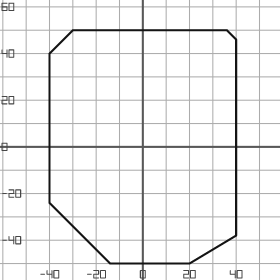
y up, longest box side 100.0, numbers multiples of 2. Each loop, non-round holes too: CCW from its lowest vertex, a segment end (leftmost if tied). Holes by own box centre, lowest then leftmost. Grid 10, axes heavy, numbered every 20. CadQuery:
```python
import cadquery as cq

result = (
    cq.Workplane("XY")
    .moveTo(-14.0, -50.0)
    .lineTo(20.0, -50.0)
    .lineTo(40.0, -38.0)
    .lineTo(40.0, 46.0)
    .lineTo(36.0, 50.0)
    .lineTo(-30.0, 50.0)
    .lineTo(-40.0, 40.0)
    .lineTo(-40.0, -24.0)
    .close()
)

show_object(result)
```